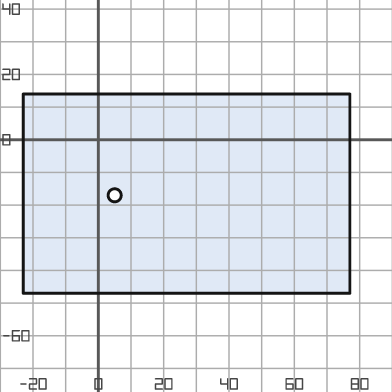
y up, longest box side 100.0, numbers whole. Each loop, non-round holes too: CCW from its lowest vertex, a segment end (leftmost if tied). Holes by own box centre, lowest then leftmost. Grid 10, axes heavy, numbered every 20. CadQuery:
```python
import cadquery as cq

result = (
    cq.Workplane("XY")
    .moveTo(-23.0, -47.0)
    .lineTo(77.0, -47.0)
    .lineTo(77.0, 14.0)
    .lineTo(-23.0, 14.0)
    .close()
    .moveTo(5.0, -17.0)
    .circle(2.0)
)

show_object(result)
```